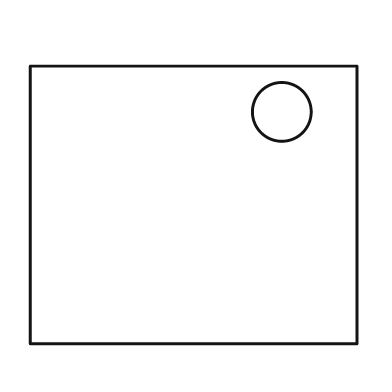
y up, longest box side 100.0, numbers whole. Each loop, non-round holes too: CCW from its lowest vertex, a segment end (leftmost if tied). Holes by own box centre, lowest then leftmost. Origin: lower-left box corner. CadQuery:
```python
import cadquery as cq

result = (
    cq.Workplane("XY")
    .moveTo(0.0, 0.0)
    .lineTo(100.0, 0.0)
    .lineTo(100.0, 85.0)
    .lineTo(0.0, 85.0)
    .close()
    .moveTo(77.0, 71.0)
    .circle(9.0)
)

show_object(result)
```